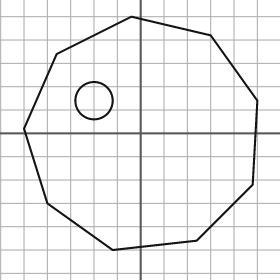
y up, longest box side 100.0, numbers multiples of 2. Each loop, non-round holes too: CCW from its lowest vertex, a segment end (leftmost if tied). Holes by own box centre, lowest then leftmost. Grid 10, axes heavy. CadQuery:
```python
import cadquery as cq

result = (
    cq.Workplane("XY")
    .moveTo(-12.0, -50.0)
    .lineTo(24.0, -46.0)
    .lineTo(48.0, -22.0)
    .lineTo(50.0, 14.0)
    .lineTo(30.0, 42.0)
    .lineTo(-4.0, 50.0)
    .lineTo(-36.0, 34.0)
    .lineTo(-50.0, 2.0)
    .lineTo(-40.0, -30.0)
    .close()
    .moveTo(-20.0, 14.0)
    .circle(8.0)
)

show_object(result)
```